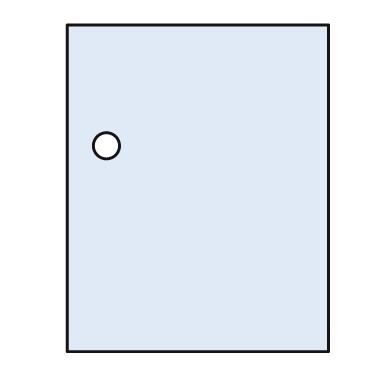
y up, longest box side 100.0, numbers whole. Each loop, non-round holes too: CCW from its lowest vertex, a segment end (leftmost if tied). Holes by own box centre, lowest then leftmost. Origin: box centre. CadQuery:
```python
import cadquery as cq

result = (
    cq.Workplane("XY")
    .moveTo(-40.0, -50.0)
    .lineTo(40.0, -50.0)
    .lineTo(40.0, 50.0)
    .lineTo(-40.0, 50.0)
    .close()
    .moveTo(-28.0, 13.0)
    .circle(4.0)
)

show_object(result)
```